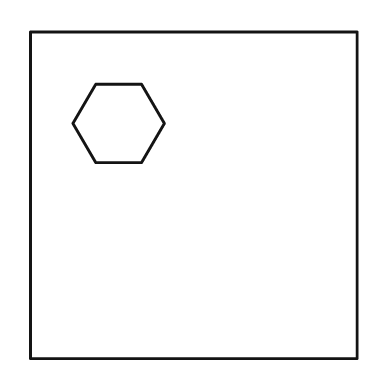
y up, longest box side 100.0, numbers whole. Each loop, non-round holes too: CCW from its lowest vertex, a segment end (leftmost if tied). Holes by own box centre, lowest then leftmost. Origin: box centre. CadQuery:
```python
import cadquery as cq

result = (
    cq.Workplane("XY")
    .moveTo(-50.0, -50.0)
    .lineTo(50.0, -50.0)
    .lineTo(50.0, 50.0)
    .lineTo(-50.0, 50.0)
    .close()
    .moveTo(-30.0, 10.0)
    .lineTo(-16.0, 10.0)
    .lineTo(-9.0, 22.0)
    .lineTo(-16.0, 34.0)
    .lineTo(-30.0, 34.0)
    .lineTo(-37.0, 22.0)
    .close()
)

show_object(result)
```